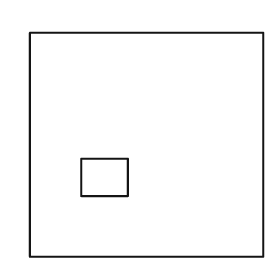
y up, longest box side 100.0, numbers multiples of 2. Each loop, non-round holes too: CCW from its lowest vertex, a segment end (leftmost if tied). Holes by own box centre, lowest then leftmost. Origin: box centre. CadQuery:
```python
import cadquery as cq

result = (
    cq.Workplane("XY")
    .moveTo(-50.0, -48.0)
    .lineTo(50.0, -48.0)
    .lineTo(50.0, 48.0)
    .lineTo(-50.0, 48.0)
    .close()
    .moveTo(-28.0, -22.0)
    .lineTo(-8.0, -22.0)
    .lineTo(-8.0, -6.0)
    .lineTo(-28.0, -6.0)
    .close()
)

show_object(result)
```